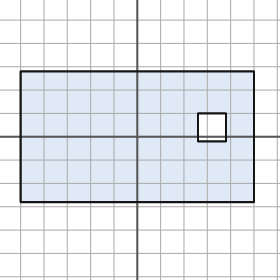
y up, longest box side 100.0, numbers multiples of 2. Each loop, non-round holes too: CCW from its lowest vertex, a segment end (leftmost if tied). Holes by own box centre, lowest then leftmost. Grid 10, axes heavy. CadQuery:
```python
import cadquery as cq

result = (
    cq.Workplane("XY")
    .moveTo(-50.0, -28.0)
    .lineTo(50.0, -28.0)
    .lineTo(50.0, 28.0)
    .lineTo(-50.0, 28.0)
    .close()
    .moveTo(26.0, -2.0)
    .lineTo(38.0, -2.0)
    .lineTo(38.0, 10.0)
    .lineTo(26.0, 10.0)
    .close()
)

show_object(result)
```